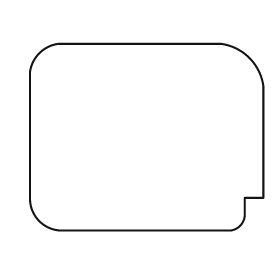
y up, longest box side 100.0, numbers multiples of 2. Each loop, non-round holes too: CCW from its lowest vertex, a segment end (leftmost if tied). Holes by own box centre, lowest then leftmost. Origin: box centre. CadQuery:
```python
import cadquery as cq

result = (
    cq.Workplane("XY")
    .moveTo(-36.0, -40.0)
    .lineTo(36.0, -40.0)
    .threePointArc((40.0, -38.0), (42.0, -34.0))
    .lineTo(42.0, -26.0)
    .lineTo(50.0, -26.0)
    .lineTo(50.0, 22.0)
    .threePointArc((44.0, 34.0), (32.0, 40.0))
    .lineTo(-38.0, 40.0)
    .threePointArc((-46.0, 36.0), (-50.0, 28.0))
    .lineTo(-50.0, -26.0)
    .threePointArc((-46.0, -36.0), (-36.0, -40.0))
    .close()
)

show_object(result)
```